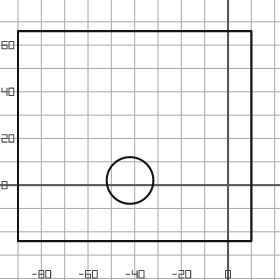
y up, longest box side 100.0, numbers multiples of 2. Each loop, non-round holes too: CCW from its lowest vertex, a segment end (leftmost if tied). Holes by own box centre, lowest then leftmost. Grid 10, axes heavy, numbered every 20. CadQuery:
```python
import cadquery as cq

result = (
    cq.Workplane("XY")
    .moveTo(-90.0, -24.0)
    .lineTo(10.0, -24.0)
    .lineTo(10.0, 66.0)
    .lineTo(-90.0, 66.0)
    .close()
    .moveTo(-42.0, 2.0)
    .circle(10.0)
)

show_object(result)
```